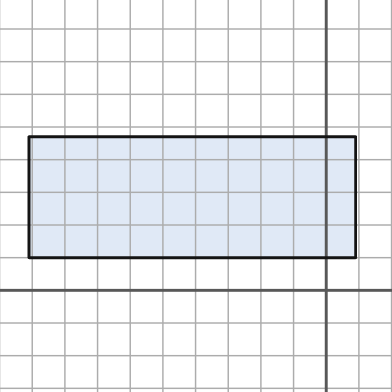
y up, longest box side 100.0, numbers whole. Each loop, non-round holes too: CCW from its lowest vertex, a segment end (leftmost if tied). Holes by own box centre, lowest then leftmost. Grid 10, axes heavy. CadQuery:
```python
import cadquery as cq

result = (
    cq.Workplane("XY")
    .moveTo(-91.0, 10.0)
    .lineTo(9.0, 10.0)
    .lineTo(9.0, 47.0)
    .lineTo(-91.0, 47.0)
    .close()
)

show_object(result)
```